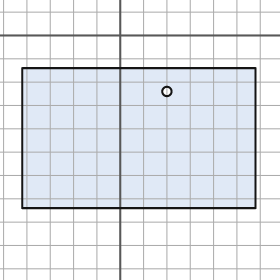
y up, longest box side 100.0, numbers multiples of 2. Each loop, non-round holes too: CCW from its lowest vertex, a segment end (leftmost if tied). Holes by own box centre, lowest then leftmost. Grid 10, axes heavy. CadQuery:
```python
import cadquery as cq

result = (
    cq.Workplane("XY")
    .moveTo(-42.0, -74.0)
    .lineTo(58.0, -74.0)
    .lineTo(58.0, -14.0)
    .lineTo(-42.0, -14.0)
    .close()
    .moveTo(20.0, -24.0)
    .circle(2.0)
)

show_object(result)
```